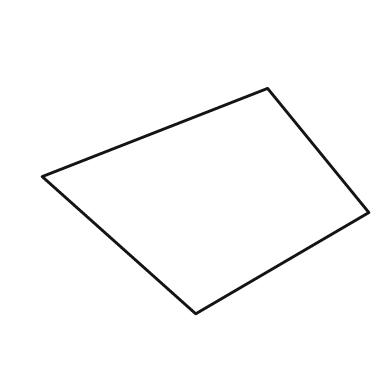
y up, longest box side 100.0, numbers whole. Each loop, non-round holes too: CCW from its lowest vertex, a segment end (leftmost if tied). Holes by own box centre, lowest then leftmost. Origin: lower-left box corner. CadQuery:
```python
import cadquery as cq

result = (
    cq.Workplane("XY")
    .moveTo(47.0, 0.0)
    .lineTo(100.0, 31.0)
    .lineTo(69.0, 69.0)
    .lineTo(0.0, 42.0)
    .close()
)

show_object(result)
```